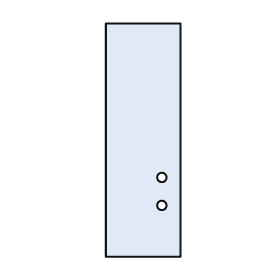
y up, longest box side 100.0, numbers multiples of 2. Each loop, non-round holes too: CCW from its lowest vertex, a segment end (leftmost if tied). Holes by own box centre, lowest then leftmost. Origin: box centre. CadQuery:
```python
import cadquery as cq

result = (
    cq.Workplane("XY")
    .moveTo(-16.0, -50.0)
    .lineTo(16.0, -50.0)
    .lineTo(16.0, 50.0)
    .lineTo(-16.0, 50.0)
    .close()
    .moveTo(8.0, -28.0)
    .circle(2.0)
    .moveTo(8.0, -16.0)
    .circle(2.0)
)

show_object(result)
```